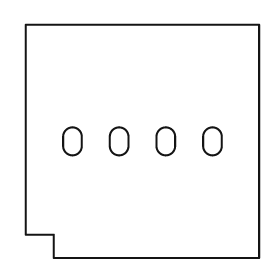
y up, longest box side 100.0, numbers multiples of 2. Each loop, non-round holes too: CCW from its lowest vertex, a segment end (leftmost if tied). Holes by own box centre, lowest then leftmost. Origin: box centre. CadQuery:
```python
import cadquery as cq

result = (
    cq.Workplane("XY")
    .moveTo(-38.0, -50.0)
    .lineTo(50.0, -50.0)
    .lineTo(50.0, 50.0)
    .lineTo(-50.0, 50.0)
    .lineTo(-50.0, -40.0)
    .lineTo(-38.0, -40.0)
    .close()
    .moveTo(-34.0, -2.0)
    .threePointArc((-30.0, -6.0), (-26.0, -2.0))
    .lineTo(-26.0, 2.0)
    .threePointArc((-30.0, 6.0), (-34.0, 2.0))
    .close()
    .moveTo(-14.0, -2.0)
    .threePointArc((-10.0, -6.0), (-6.0, -2.0))
    .lineTo(-6.0, 2.0)
    .threePointArc((-10.0, 6.0), (-14.0, 2.0))
    .close()
    .moveTo(6.0, -2.0)
    .threePointArc((10.0, -6.0), (14.0, -2.0))
    .lineTo(14.0, 2.0)
    .threePointArc((10.0, 6.0), (6.0, 2.0))
    .close()
    .moveTo(26.0, -2.0)
    .threePointArc((30.0, -6.0), (34.0, -2.0))
    .lineTo(34.0, 2.0)
    .threePointArc((30.0, 6.0), (26.0, 2.0))
    .close()
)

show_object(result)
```